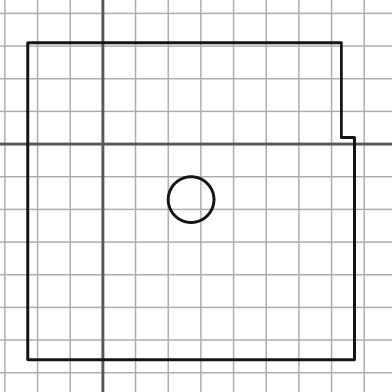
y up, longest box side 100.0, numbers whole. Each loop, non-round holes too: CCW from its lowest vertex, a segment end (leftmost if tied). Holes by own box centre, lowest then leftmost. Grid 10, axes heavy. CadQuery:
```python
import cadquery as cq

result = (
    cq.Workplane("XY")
    .moveTo(-23.0, -66.0)
    .lineTo(77.0, -66.0)
    .lineTo(77.0, 2.0)
    .lineTo(73.0, 2.0)
    .lineTo(73.0, 31.0)
    .lineTo(-23.0, 31.0)
    .close()
    .moveTo(27.0, -17.0)
    .circle(7.0)
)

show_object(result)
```